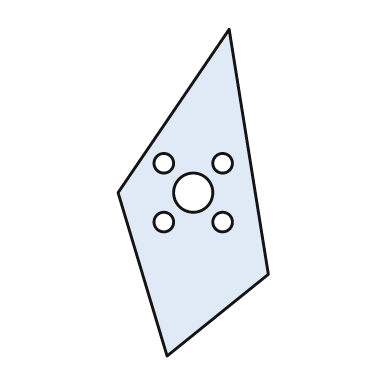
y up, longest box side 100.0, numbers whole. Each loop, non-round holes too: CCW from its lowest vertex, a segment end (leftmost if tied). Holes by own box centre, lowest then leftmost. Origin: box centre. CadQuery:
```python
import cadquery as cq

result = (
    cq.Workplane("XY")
    .moveTo(-8.0, -50.0)
    .lineTo(23.0, -25.0)
    .lineTo(11.0, 50.0)
    .lineTo(-23.0, 0.0)
    .close()
    .moveTo(-9.0, -9.0)
    .circle(3.0)
    .moveTo(9.0, -9.0)
    .circle(3.0)
    .moveTo(0.0, 0.0)
    .circle(6.0)
    .moveTo(-9.0, 9.0)
    .circle(3.0)
    .moveTo(9.0, 9.0)
    .circle(3.0)
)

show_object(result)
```